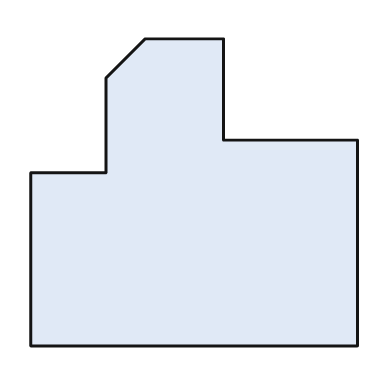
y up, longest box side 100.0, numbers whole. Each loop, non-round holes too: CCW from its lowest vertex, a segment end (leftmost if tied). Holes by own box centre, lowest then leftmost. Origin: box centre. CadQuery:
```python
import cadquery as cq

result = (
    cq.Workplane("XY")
    .moveTo(-50.0, -47.0)
    .lineTo(50.0, -47.0)
    .lineTo(50.0, 16.0)
    .lineTo(9.0, 16.0)
    .lineTo(9.0, 47.0)
    .lineTo(-15.0, 47.0)
    .lineTo(-27.0, 35.0)
    .lineTo(-27.0, 6.0)
    .lineTo(-50.0, 6.0)
    .close()
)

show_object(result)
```